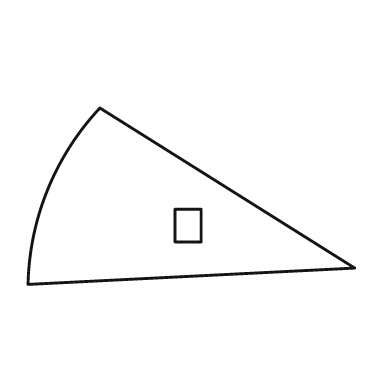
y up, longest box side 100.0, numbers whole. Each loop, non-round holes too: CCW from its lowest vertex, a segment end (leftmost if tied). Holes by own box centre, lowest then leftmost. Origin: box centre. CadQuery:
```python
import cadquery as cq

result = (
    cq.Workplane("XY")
    .moveTo(-50.0, -27.0)
    .lineTo(50.0, -22.0)
    .lineTo(-28.0, 27.0)
    .threePointArc((-44.0, 2.0), (-50.0, -27.0))
    .close()
    .moveTo(-5.0, -14.0)
    .lineTo(3.0, -14.0)
    .lineTo(3.0, -4.0)
    .lineTo(-5.0, -4.0)
    .close()
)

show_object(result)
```